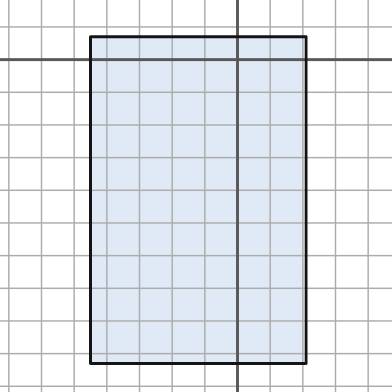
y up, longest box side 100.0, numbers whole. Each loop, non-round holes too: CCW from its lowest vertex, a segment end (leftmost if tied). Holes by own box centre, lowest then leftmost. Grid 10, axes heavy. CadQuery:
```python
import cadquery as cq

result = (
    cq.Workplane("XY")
    .moveTo(-45.0, -93.0)
    .lineTo(21.0, -93.0)
    .lineTo(21.0, 7.0)
    .lineTo(-45.0, 7.0)
    .close()
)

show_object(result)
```